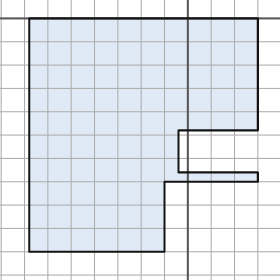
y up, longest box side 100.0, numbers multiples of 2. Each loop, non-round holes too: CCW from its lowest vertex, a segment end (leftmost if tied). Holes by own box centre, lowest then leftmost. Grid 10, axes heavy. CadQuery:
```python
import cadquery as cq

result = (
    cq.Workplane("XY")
    .moveTo(-68.0, -100.0)
    .lineTo(-10.0, -100.0)
    .lineTo(-10.0, -70.0)
    .lineTo(30.0, -70.0)
    .lineTo(30.0, -66.0)
    .lineTo(-4.0, -66.0)
    .lineTo(-4.0, -48.0)
    .lineTo(30.0, -48.0)
    .lineTo(30.0, 0.0)
    .lineTo(-68.0, 0.0)
    .close()
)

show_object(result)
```